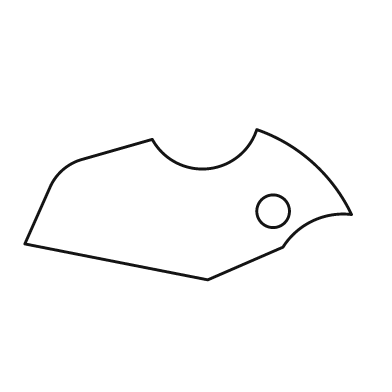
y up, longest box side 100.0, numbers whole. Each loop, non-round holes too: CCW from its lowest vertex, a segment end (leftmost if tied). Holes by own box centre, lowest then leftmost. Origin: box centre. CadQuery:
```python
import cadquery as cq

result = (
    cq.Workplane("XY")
    .moveTo(6.0, -23.0)
    .lineTo(29.0, -13.0)
    .threePointArc((38.0, -5.0), (50.0, -3.0))
    .threePointArc((38.0, 13.0), (21.0, 23.0))
    .threePointArc((6.0, 11.0), (-11.0, 20.0))
    .lineTo(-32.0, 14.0)
    .threePointArc((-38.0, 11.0), (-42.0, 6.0))
    .lineTo(-50.0, -12.0)
    .close()
    .moveTo(26.0, -2.0)
    .circle(5.0)
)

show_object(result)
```